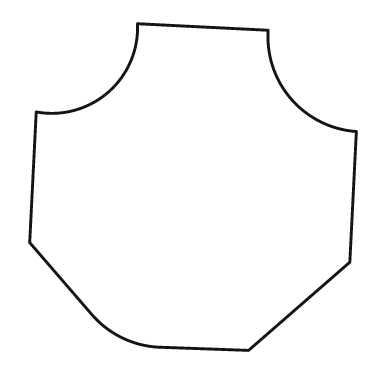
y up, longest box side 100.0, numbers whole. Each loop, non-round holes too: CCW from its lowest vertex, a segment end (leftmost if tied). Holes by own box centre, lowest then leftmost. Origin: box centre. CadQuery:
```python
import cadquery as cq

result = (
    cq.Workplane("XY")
    .moveTo(17.0, -50.0)
    .lineTo(48.0, -23.0)
    .lineTo(50.0, 17.0)
    .threePointArc((30.0, 27.0), (23.0, 48.0))
    .lineTo(-17.0, 50.0)
    .threePointArc((-26.0, 29.0), (-48.0, 23.0))
    .lineTo(-50.0, -17.0)
    .lineTo(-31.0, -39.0)
    .threePointArc((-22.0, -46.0), (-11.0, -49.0))
    .close()
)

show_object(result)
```